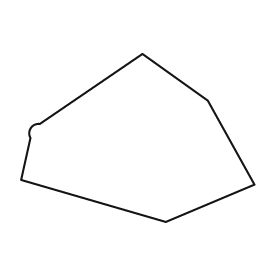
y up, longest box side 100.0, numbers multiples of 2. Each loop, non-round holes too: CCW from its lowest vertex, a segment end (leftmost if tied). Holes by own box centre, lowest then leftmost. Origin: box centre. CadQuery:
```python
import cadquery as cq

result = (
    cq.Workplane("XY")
    .moveTo(12.0, -36.0)
    .lineTo(50.0, -20.0)
    .lineTo(30.0, 16.0)
    .lineTo(2.0, 36.0)
    .lineTo(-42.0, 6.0)
    .threePointArc((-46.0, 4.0), (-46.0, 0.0))
    .lineTo(-50.0, -18.0)
    .close()
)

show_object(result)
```